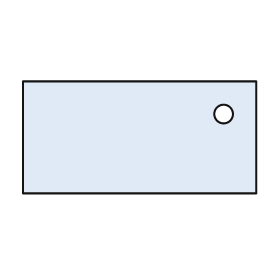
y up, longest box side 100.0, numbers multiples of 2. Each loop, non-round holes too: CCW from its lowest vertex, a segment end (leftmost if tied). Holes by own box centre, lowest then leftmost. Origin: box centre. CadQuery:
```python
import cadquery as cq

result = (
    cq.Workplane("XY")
    .moveTo(-50.0, -24.0)
    .lineTo(50.0, -24.0)
    .lineTo(50.0, 24.0)
    .lineTo(-50.0, 24.0)
    .close()
    .moveTo(36.0, 10.0)
    .circle(4.0)
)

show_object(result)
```